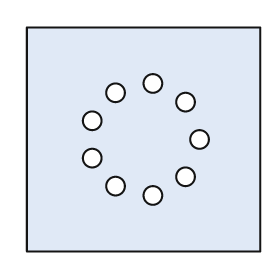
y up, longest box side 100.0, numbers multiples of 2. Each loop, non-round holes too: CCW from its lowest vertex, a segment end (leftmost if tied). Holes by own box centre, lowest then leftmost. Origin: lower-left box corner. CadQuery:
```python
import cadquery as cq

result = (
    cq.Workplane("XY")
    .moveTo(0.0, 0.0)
    .lineTo(100.0, 0.0)
    .lineTo(100.0, 96.0)
    .lineTo(0.0, 96.0)
    .close()
    .moveTo(54.0, 24.0)
    .circle(4.0)
    .moveTo(38.0, 28.0)
    .circle(4.0)
    .moveTo(68.0, 32.0)
    .circle(4.0)
    .moveTo(28.0, 40.0)
    .circle(4.0)
    .moveTo(74.0, 48.0)
    .circle(4.0)
    .moveTo(28.0, 56.0)
    .circle(4.0)
    .moveTo(68.0, 64.0)
    .circle(4.0)
    .moveTo(38.0, 68.0)
    .circle(4.0)
    .moveTo(54.0, 72.0)
    .circle(4.0)
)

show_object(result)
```